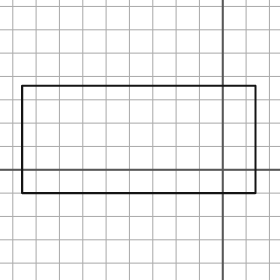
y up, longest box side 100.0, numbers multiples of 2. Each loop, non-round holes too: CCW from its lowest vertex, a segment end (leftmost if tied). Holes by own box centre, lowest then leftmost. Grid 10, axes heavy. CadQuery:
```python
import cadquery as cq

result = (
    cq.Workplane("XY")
    .moveTo(-86.0, -10.0)
    .lineTo(14.0, -10.0)
    .lineTo(14.0, 36.0)
    .lineTo(-86.0, 36.0)
    .close()
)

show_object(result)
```